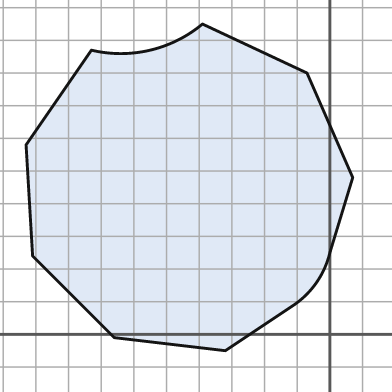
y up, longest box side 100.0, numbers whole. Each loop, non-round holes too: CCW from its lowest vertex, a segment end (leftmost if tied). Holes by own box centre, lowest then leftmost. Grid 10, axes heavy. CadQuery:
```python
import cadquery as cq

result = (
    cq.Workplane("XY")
    .moveTo(-32.0, -5.0)
    .lineTo(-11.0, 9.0)
    .threePointArc((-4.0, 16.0), (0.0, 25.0))
    .lineTo(7.0, 48.0)
    .lineTo(-7.0, 80.0)
    .lineTo(-39.0, 95.0)
    .threePointArc((-55.0, 87.0), (-73.0, 87.0))
    .lineTo(-93.0, 58.0)
    .lineTo(-91.0, 24.0)
    .lineTo(-66.0, -1.0)
    .close()
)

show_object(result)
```